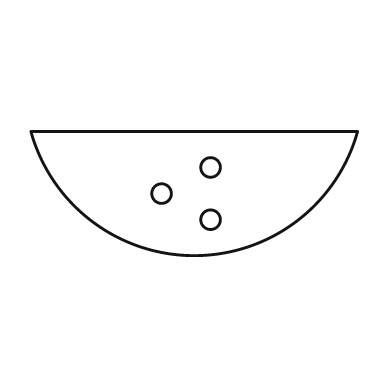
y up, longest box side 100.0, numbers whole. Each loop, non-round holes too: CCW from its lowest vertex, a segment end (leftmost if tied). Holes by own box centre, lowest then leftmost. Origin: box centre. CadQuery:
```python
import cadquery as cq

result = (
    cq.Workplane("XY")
    .moveTo(-50.0, 19.0)
    .threePointArc((0.0, -19.0), (50.0, 19.0))
    .close()
    .moveTo(5.0, -8.0)
    .circle(3.0)
    .moveTo(-10.0, 0.0)
    .circle(3.0)
    .moveTo(5.0, 8.0)
    .circle(3.0)
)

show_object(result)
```